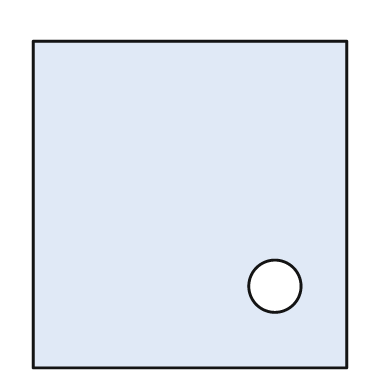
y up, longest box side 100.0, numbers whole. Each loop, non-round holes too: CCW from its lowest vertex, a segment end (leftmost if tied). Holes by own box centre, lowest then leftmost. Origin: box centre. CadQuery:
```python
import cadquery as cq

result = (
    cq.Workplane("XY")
    .moveTo(-48.0, -50.0)
    .lineTo(48.0, -50.0)
    .lineTo(48.0, 50.0)
    .lineTo(-48.0, 50.0)
    .close()
    .moveTo(26.0, -25.0)
    .circle(8.0)
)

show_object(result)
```